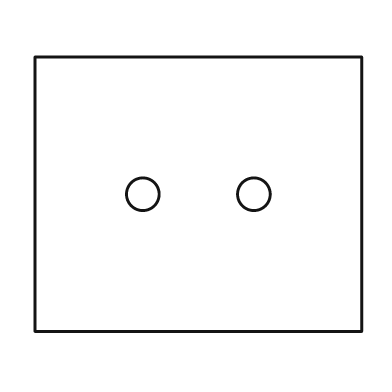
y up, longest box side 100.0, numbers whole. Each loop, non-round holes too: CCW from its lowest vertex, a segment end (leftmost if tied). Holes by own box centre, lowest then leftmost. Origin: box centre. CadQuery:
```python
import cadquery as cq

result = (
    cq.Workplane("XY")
    .moveTo(-50.0, -42.0)
    .lineTo(50.0, -42.0)
    .lineTo(50.0, 42.0)
    .lineTo(-50.0, 42.0)
    .close()
    .moveTo(-17.0, 0.0)
    .circle(5.0)
    .moveTo(17.0, 0.0)
    .circle(5.0)
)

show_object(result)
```